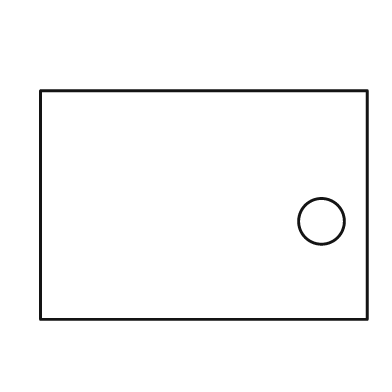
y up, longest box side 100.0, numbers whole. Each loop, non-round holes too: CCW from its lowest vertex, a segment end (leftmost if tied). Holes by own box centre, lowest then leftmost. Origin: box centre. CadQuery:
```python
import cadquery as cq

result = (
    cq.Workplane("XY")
    .moveTo(-50.0, -35.0)
    .lineTo(50.0, -35.0)
    .lineTo(50.0, 35.0)
    .lineTo(-50.0, 35.0)
    .close()
    .moveTo(36.0, -5.0)
    .circle(7.0)
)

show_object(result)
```